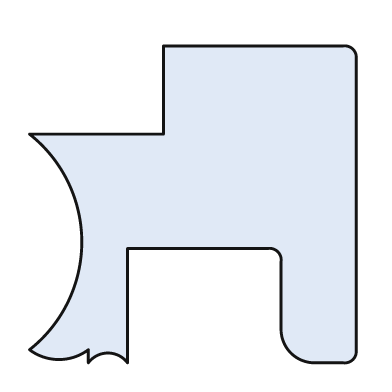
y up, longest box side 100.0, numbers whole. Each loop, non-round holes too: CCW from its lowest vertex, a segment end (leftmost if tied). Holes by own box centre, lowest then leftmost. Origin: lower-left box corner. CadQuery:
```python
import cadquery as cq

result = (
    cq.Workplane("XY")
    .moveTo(18.0, 0.0)
    .threePointArc((24.0, 3.0), (30.0, 0.0))
    .lineTo(30.0, 35.0)
    .lineTo(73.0, 35.0)
    .threePointArc((76.0, 34.0), (77.0, 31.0))
    .lineTo(77.0, 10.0)
    .threePointArc((80.0, 3.0), (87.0, 0.0))
    .lineTo(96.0, 0.0)
    .threePointArc((99.0, 1.0), (100.0, 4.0))
    .lineTo(100.0, 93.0)
    .threePointArc((99.0, 96.0), (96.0, 97.0))
    .lineTo(41.0, 97.0)
    .lineTo(41.0, 70.0)
    .lineTo(0.0, 70.0)
    .threePointArc((16.0, 37.0), (0.0, 4.0))
    .threePointArc((9.0, 1.0), (18.0, 4.0))
    .close()
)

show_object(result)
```